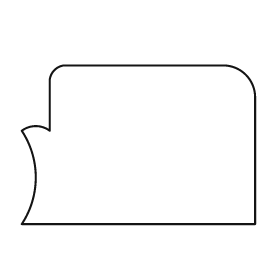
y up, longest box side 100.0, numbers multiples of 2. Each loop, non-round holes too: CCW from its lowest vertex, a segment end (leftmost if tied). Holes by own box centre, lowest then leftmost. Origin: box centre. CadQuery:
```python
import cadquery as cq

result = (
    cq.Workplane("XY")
    .moveTo(-50.0, -34.0)
    .lineTo(50.0, -34.0)
    .lineTo(50.0, 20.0)
    .threePointArc((46.0, 30.0), (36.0, 34.0))
    .lineTo(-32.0, 34.0)
    .threePointArc((-36.0, 32.0), (-38.0, 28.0))
    .lineTo(-38.0, 6.0)
    .threePointArc((-44.0, 8.0), (-50.0, 6.0))
    .threePointArc((-44.0, -14.0), (-50.0, -34.0))
    .close()
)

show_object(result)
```